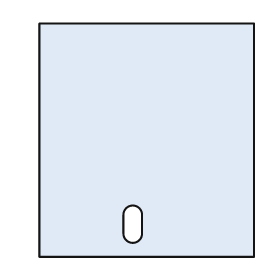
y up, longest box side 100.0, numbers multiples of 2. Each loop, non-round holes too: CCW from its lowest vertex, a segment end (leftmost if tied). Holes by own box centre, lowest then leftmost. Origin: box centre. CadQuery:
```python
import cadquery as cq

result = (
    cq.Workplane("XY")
    .moveTo(-46.0, -50.0)
    .lineTo(46.0, -50.0)
    .lineTo(46.0, 50.0)
    .lineTo(-46.0, 50.0)
    .close()
    .moveTo(-10.0, -40.0)
    .threePointArc((-6.0, -44.0), (-2.0, -40.0))
    .lineTo(-2.0, -32.0)
    .threePointArc((-6.0, -28.0), (-10.0, -32.0))
    .close()
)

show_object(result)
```